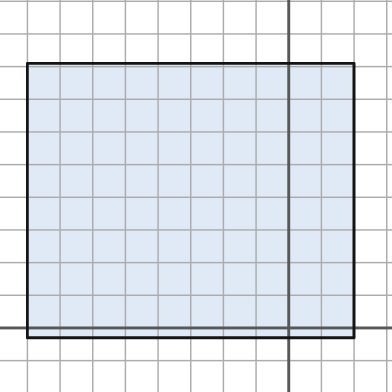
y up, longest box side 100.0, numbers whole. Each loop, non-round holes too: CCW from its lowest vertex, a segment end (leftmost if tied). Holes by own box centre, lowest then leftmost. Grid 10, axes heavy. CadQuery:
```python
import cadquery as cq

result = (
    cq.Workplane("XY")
    .moveTo(-80.0, -3.0)
    .lineTo(20.0, -3.0)
    .lineTo(20.0, 81.0)
    .lineTo(-80.0, 81.0)
    .close()
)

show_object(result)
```